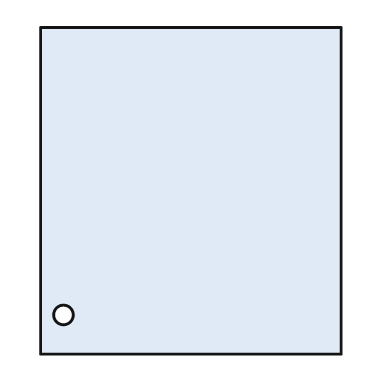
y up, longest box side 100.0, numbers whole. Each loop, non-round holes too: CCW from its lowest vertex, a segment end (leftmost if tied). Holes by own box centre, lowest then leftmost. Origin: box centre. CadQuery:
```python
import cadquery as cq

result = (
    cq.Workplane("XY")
    .moveTo(-46.0, -50.0)
    .lineTo(46.0, -50.0)
    .lineTo(46.0, 50.0)
    .lineTo(-46.0, 50.0)
    .close()
    .moveTo(-39.0, -38.0)
    .circle(3.0)
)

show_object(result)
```